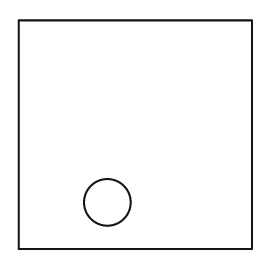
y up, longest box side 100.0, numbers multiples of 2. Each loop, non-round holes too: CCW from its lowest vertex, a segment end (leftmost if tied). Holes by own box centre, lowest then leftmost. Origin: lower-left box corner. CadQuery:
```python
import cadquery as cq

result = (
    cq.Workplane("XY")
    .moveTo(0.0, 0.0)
    .lineTo(100.0, 0.0)
    .lineTo(100.0, 98.0)
    .lineTo(0.0, 98.0)
    .close()
    .moveTo(38.0, 20.0)
    .circle(10.0)
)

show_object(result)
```